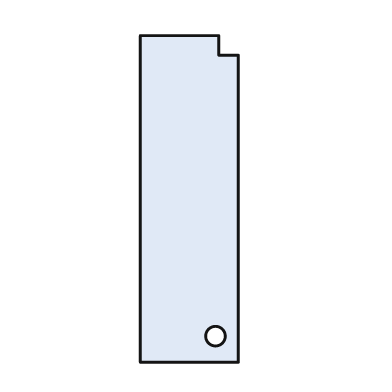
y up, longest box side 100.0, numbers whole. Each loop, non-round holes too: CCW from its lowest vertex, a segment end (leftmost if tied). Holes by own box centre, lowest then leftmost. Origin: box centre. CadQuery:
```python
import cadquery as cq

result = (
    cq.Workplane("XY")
    .moveTo(-15.0, -50.0)
    .lineTo(15.0, -50.0)
    .lineTo(15.0, 44.0)
    .lineTo(9.0, 44.0)
    .lineTo(9.0, 50.0)
    .lineTo(-15.0, 50.0)
    .close()
    .moveTo(8.0, -42.0)
    .circle(3.0)
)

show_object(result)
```